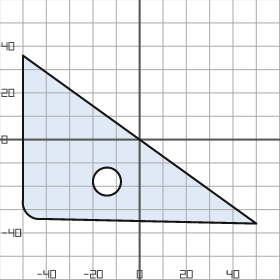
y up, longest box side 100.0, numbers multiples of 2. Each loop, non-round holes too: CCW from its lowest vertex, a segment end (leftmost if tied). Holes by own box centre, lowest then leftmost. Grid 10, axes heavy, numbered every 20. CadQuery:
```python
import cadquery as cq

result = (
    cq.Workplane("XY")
    .moveTo(50.0, -36.0)
    .lineTo(-50.0, 36.0)
    .lineTo(-50.0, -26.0)
    .threePointArc((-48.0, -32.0), (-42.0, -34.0))
    .close()
    .moveTo(-14.0, -18.0)
    .circle(6.0)
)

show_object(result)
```